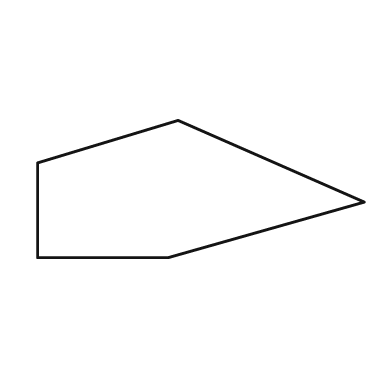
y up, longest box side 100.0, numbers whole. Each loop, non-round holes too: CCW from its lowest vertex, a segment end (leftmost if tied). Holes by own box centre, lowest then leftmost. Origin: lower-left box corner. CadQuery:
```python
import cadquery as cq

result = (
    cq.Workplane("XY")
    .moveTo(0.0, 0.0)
    .lineTo(40.0, 0.0)
    .lineTo(100.0, 17.0)
    .lineTo(43.0, 42.0)
    .lineTo(0.0, 29.0)
    .close()
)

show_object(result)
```